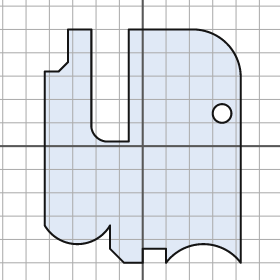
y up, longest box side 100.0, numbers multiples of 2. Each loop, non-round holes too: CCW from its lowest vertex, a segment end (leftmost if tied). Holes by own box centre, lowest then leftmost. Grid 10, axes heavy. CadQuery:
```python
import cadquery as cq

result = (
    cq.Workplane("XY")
    .moveTo(-8.0, -50.0)
    .lineTo(0.0, -50.0)
    .lineTo(0.0, -44.0)
    .lineTo(10.0, -44.0)
    .lineTo(10.0, -50.0)
    .threePointArc((26.0, -42.0), (42.0, -50.0))
    .lineTo(42.0, 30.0)
    .threePointArc((36.0, 44.0), (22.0, 50.0))
    .lineTo(-6.0, 50.0)
    .lineTo(-6.0, 2.0)
    .lineTo(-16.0, 2.0)
    .threePointArc((-20.0, 4.0), (-22.0, 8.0))
    .lineTo(-22.0, 50.0)
    .lineTo(-32.0, 50.0)
    .lineTo(-32.0, 36.0)
    .lineTo(-36.0, 32.0)
    .lineTo(-42.0, 32.0)
    .lineTo(-42.0, -34.0)
    .threePointArc((-28.0, -42.0), (-14.0, -34.0))
    .lineTo(-14.0, -44.0)
    .close()
    .moveTo(34.0, 14.0)
    .circle(4.0)
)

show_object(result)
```